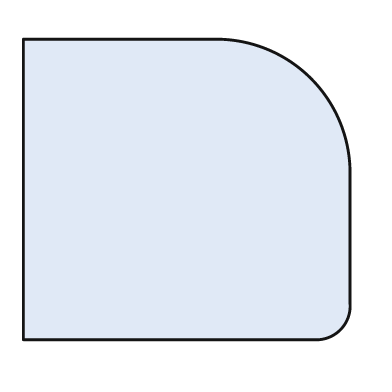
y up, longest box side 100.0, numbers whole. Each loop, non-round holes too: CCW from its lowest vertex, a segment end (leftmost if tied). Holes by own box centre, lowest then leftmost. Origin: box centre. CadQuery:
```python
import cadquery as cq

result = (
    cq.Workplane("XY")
    .moveTo(-50.0, -46.0)
    .lineTo(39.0, -46.0)
    .threePointArc((47.0, -43.0), (50.0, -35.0))
    .lineTo(50.0, 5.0)
    .threePointArc((38.0, 34.0), (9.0, 46.0))
    .lineTo(-50.0, 46.0)
    .close()
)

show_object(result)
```